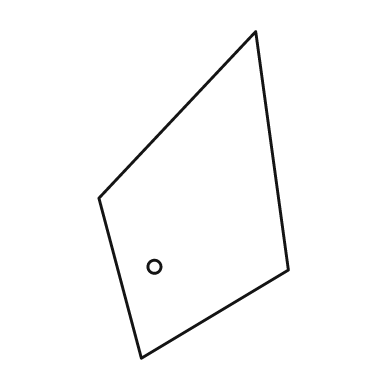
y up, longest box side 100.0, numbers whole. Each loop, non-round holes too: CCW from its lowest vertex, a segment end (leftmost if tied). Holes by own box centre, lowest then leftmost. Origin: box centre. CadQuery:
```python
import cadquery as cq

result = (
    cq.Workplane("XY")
    .moveTo(-16.0, -50.0)
    .lineTo(29.0, -23.0)
    .lineTo(19.0, 50.0)
    .lineTo(-29.0, -1.0)
    .close()
    .moveTo(-12.0, -22.0)
    .circle(2.0)
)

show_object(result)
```